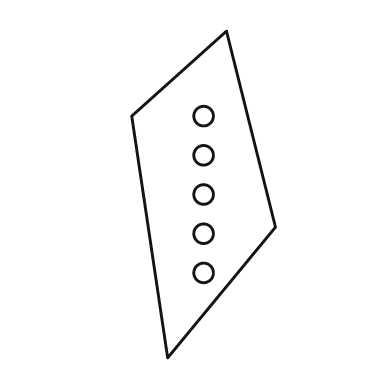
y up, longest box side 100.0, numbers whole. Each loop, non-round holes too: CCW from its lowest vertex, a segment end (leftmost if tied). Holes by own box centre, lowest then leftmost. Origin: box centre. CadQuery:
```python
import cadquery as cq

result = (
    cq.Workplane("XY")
    .moveTo(-11.0, -50.0)
    .lineTo(22.0, -10.0)
    .lineTo(7.0, 50.0)
    .lineTo(-22.0, 24.0)
    .close()
    .moveTo(0.0, -24.0)
    .circle(3.0)
    .moveTo(0.0, -12.0)
    .circle(3.0)
    .moveTo(0.0, 0.0)
    .circle(3.0)
    .moveTo(0.0, 12.0)
    .circle(3.0)
    .moveTo(0.0, 24.0)
    .circle(3.0)
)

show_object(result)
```